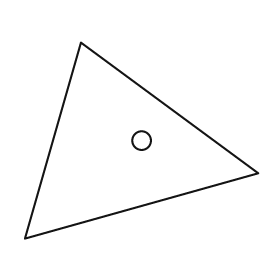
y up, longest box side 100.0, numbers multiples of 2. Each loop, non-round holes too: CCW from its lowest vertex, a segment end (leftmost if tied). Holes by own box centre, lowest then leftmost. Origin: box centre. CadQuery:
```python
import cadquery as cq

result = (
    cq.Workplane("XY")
    .moveTo(-50.0, -42.0)
    .lineTo(50.0, -14.0)
    .lineTo(-26.0, 42.0)
    .close()
    .moveTo(0.0, 0.0)
    .circle(4.0)
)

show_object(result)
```